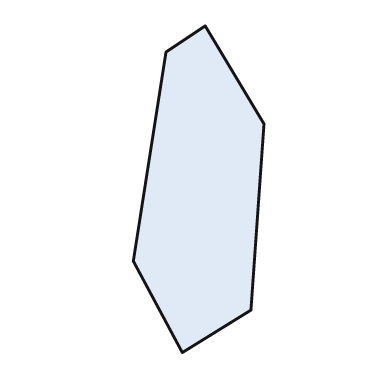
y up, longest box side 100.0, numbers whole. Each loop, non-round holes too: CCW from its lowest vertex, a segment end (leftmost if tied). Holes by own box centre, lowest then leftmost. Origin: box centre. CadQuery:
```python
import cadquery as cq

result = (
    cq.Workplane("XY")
    .moveTo(-5.0, -50.0)
    .lineTo(16.0, -37.0)
    .lineTo(20.0, 20.0)
    .lineTo(2.0, 50.0)
    .lineTo(-10.0, 42.0)
    .lineTo(-20.0, -22.0)
    .close()
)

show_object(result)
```